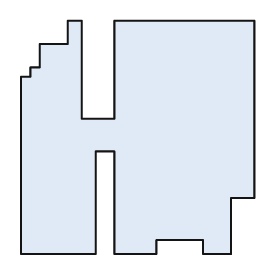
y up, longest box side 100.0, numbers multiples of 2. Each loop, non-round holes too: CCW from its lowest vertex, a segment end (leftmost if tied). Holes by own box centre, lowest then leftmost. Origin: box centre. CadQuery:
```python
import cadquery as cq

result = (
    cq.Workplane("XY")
    .moveTo(-50.0, -50.0)
    .lineTo(-18.0, -50.0)
    .lineTo(-18.0, -6.0)
    .lineTo(-10.0, -6.0)
    .lineTo(-10.0, -50.0)
    .lineTo(8.0, -50.0)
    .lineTo(8.0, -44.0)
    .lineTo(28.0, -44.0)
    .lineTo(28.0, -50.0)
    .lineTo(40.0, -50.0)
    .lineTo(40.0, -26.0)
    .lineTo(50.0, -26.0)
    .lineTo(50.0, 50.0)
    .lineTo(-10.0, 50.0)
    .lineTo(-10.0, 8.0)
    .lineTo(-24.0, 8.0)
    .lineTo(-24.0, 50.0)
    .lineTo(-30.0, 50.0)
    .lineTo(-30.0, 40.0)
    .lineTo(-42.0, 40.0)
    .lineTo(-42.0, 30.0)
    .lineTo(-46.0, 30.0)
    .lineTo(-46.0, 26.0)
    .lineTo(-50.0, 26.0)
    .close()
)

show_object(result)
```